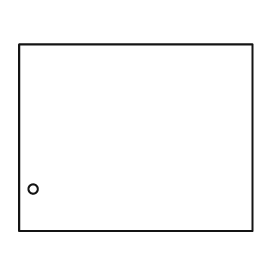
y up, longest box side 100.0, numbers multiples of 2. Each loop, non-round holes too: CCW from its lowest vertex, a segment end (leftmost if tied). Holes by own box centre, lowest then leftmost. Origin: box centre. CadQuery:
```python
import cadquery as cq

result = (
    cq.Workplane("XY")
    .moveTo(-50.0, -40.0)
    .lineTo(50.0, -40.0)
    .lineTo(50.0, 40.0)
    .lineTo(-50.0, 40.0)
    .close()
    .moveTo(-44.0, -22.0)
    .circle(2.0)
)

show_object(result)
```